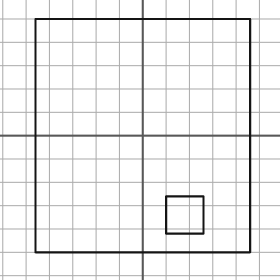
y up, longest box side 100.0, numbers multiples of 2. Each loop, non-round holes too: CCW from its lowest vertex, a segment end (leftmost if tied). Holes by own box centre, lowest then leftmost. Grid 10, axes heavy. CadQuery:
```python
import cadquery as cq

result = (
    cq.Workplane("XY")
    .moveTo(-46.0, -50.0)
    .lineTo(46.0, -50.0)
    .lineTo(46.0, 50.0)
    .lineTo(-46.0, 50.0)
    .close()
    .moveTo(10.0, -42.0)
    .lineTo(26.0, -42.0)
    .lineTo(26.0, -26.0)
    .lineTo(10.0, -26.0)
    .close()
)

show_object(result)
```